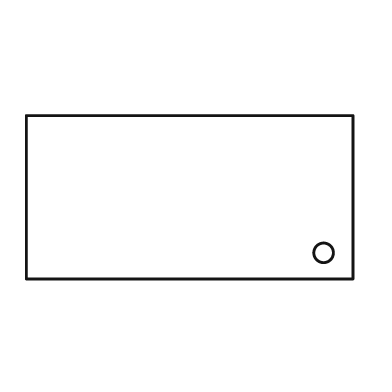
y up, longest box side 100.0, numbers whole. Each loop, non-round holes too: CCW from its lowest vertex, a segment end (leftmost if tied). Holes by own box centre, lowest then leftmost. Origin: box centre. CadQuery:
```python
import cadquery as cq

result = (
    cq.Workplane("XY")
    .moveTo(-50.0, -25.0)
    .lineTo(50.0, -25.0)
    .lineTo(50.0, 25.0)
    .lineTo(-50.0, 25.0)
    .close()
    .moveTo(41.0, -17.0)
    .circle(3.0)
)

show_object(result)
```